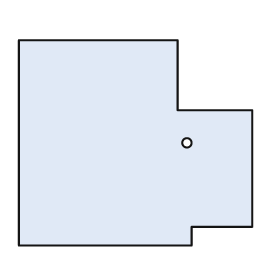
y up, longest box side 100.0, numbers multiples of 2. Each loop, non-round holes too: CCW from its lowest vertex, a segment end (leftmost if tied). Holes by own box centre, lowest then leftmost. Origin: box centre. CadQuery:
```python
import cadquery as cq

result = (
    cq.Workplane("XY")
    .moveTo(-50.0, -44.0)
    .lineTo(24.0, -44.0)
    .lineTo(24.0, -36.0)
    .lineTo(50.0, -36.0)
    .lineTo(50.0, 14.0)
    .lineTo(18.0, 14.0)
    .lineTo(18.0, 44.0)
    .lineTo(-50.0, 44.0)
    .close()
    .moveTo(22.0, 0.0)
    .circle(2.0)
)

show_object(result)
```